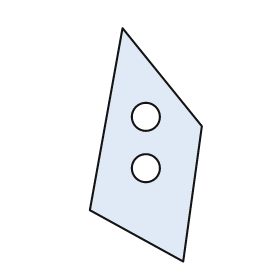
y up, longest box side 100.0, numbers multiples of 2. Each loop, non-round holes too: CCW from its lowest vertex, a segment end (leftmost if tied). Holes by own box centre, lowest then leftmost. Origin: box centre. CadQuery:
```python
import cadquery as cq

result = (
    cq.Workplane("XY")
    .moveTo(16.0, -50.0)
    .lineTo(24.0, 8.0)
    .lineTo(-10.0, 50.0)
    .lineTo(-24.0, -28.0)
    .close()
    .moveTo(0.0, -10.0)
    .circle(6.0)
    .moveTo(0.0, 12.0)
    .circle(6.0)
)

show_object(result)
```